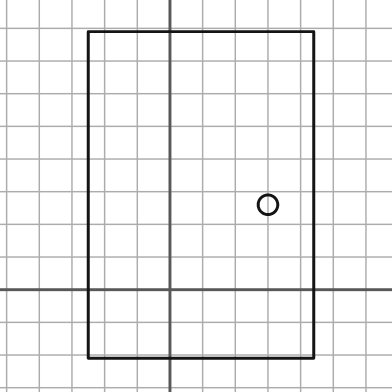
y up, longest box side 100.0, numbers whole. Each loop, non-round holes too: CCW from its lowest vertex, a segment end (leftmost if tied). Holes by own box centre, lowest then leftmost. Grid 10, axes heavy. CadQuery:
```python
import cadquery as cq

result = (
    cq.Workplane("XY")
    .moveTo(-25.0, -21.0)
    .lineTo(44.0, -21.0)
    .lineTo(44.0, 79.0)
    .lineTo(-25.0, 79.0)
    .close()
    .moveTo(30.0, 26.0)
    .circle(3.0)
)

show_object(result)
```